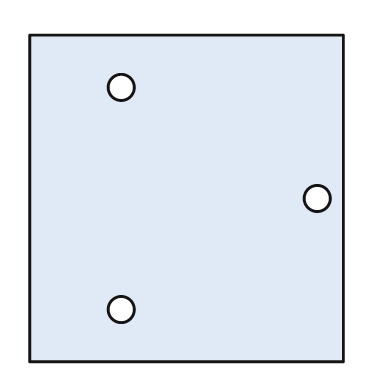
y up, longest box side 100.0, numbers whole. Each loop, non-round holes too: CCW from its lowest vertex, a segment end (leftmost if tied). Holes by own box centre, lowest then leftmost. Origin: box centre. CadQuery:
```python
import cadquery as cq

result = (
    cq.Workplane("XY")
    .moveTo(-48.0, -50.0)
    .lineTo(48.0, -50.0)
    .lineTo(48.0, 50.0)
    .lineTo(-48.0, 50.0)
    .close()
    .moveTo(-20.0, -34.0)
    .circle(4.0)
    .moveTo(40.0, 0.0)
    .circle(4.0)
    .moveTo(-20.0, 34.0)
    .circle(4.0)
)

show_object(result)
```